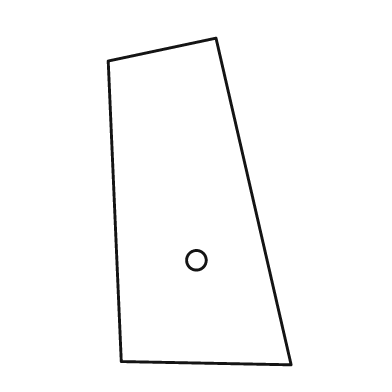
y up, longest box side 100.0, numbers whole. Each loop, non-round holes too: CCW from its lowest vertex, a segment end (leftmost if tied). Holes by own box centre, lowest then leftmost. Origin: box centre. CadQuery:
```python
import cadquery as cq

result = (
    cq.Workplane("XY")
    .moveTo(28.0, -50.0)
    .lineTo(5.0, 50.0)
    .lineTo(-28.0, 43.0)
    .lineTo(-24.0, -49.0)
    .close()
    .moveTo(-1.0, -18.0)
    .circle(3.0)
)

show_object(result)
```